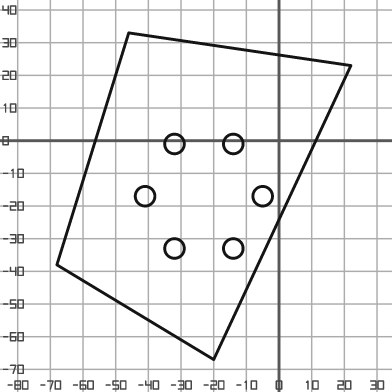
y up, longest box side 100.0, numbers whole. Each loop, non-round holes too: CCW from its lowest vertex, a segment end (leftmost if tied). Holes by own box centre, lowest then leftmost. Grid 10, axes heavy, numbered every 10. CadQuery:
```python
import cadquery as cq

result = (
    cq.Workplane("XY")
    .moveTo(-20.0, -67.0)
    .lineTo(22.0, 23.0)
    .lineTo(-46.0, 33.0)
    .lineTo(-68.0, -38.0)
    .close()
    .moveTo(-32.0, -33.0)
    .circle(3.0)
    .moveTo(-14.0, -33.0)
    .circle(3.0)
    .moveTo(-41.0, -17.0)
    .circle(3.0)
    .moveTo(-5.0, -17.0)
    .circle(3.0)
    .moveTo(-32.0, -1.0)
    .circle(3.0)
    .moveTo(-14.0, -1.0)
    .circle(3.0)
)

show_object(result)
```